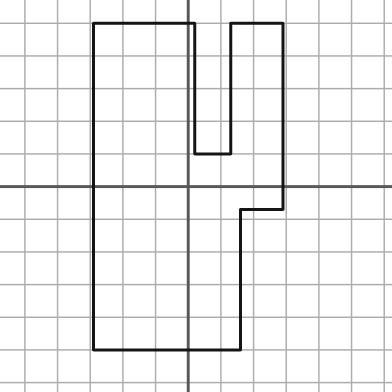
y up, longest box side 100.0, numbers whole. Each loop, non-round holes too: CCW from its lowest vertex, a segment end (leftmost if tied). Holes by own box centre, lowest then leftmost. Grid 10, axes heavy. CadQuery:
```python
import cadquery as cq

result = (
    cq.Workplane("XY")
    .moveTo(-29.0, -50.0)
    .lineTo(16.0, -50.0)
    .lineTo(16.0, -7.0)
    .lineTo(29.0, -7.0)
    .lineTo(29.0, 50.0)
    .lineTo(13.0, 50.0)
    .lineTo(13.0, 10.0)
    .lineTo(2.0, 10.0)
    .lineTo(2.0, 50.0)
    .lineTo(-29.0, 50.0)
    .close()
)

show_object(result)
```